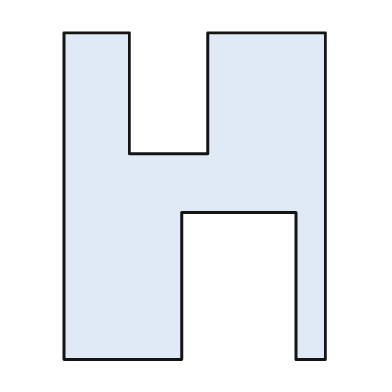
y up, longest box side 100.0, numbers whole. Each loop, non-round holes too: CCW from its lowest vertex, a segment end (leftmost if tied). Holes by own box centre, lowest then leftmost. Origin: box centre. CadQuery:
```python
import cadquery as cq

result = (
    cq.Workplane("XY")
    .moveTo(-40.0, -50.0)
    .lineTo(-4.0, -50.0)
    .lineTo(-4.0, -5.0)
    .lineTo(31.0, -5.0)
    .lineTo(31.0, -50.0)
    .lineTo(40.0, -50.0)
    .lineTo(40.0, 50.0)
    .lineTo(4.0, 50.0)
    .lineTo(4.0, 13.0)
    .lineTo(-20.0, 13.0)
    .lineTo(-20.0, 50.0)
    .lineTo(-40.0, 50.0)
    .close()
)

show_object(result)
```